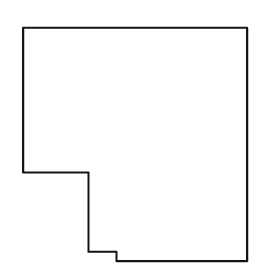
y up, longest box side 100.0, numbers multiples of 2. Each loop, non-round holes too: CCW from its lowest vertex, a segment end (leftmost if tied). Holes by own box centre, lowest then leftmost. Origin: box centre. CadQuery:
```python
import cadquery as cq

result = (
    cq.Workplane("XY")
    .moveTo(-8.0, -50.0)
    .lineTo(48.0, -50.0)
    .lineTo(48.0, 50.0)
    .lineTo(-48.0, 50.0)
    .lineTo(-48.0, -12.0)
    .lineTo(-20.0, -12.0)
    .lineTo(-20.0, -46.0)
    .lineTo(-8.0, -46.0)
    .close()
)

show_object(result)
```